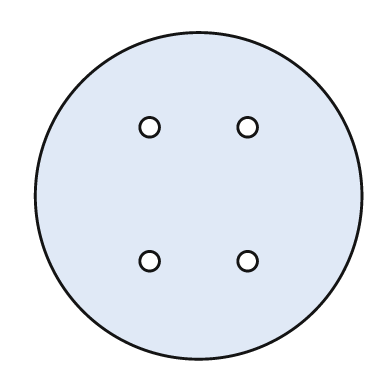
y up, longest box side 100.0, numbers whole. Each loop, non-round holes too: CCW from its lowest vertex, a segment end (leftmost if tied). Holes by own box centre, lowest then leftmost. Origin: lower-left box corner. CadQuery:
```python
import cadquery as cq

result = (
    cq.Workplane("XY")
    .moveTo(50.0, 50.0)
    .circle(50.0)
    .moveTo(35.0, 30.0)
    .circle(3.0)
    .moveTo(65.0, 30.0)
    .circle(3.0)
    .moveTo(35.0, 71.0)
    .circle(3.0)
    .moveTo(65.0, 71.0)
    .circle(3.0)
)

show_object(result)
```